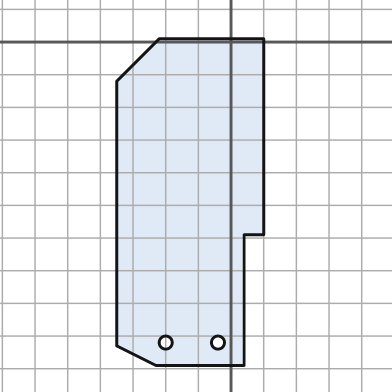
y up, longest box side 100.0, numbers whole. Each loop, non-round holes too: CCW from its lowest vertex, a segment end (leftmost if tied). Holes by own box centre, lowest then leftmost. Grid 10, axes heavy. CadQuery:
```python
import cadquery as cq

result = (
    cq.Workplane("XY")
    .moveTo(-23.0, -99.0)
    .lineTo(4.0, -99.0)
    .lineTo(4.0, -59.0)
    .lineTo(10.0, -59.0)
    .lineTo(10.0, 1.0)
    .lineTo(-22.0, 1.0)
    .lineTo(-35.0, -12.0)
    .lineTo(-35.0, -93.0)
    .close()
    .moveTo(-20.0, -92.0)
    .circle(2.0)
    .moveTo(-4.0, -92.0)
    .circle(2.0)
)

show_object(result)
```